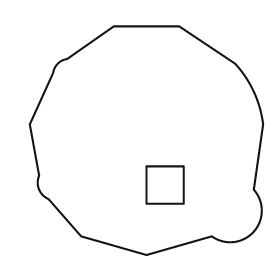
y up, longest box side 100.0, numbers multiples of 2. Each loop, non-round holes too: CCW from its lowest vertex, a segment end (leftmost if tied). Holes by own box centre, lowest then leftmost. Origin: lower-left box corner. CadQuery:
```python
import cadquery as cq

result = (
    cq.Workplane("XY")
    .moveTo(50.0, 0.0)
    .lineTo(78.0, 8.0)
    .threePointArc((96.0, 10.0), (96.0, 28.0))
    .lineTo(100.0, 56.0)
    .threePointArc((96.0, 70.0), (88.0, 82.0))
    .lineTo(64.0, 98.0)
    .lineTo(36.0, 98.0)
    .lineTo(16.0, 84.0)
    .threePointArc((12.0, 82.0), (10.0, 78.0))
    .lineTo(0.0, 56.0)
    .lineTo(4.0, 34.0)
    .threePointArc((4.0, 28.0), (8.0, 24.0))
    .lineTo(22.0, 8.0)
    .close()
    .moveTo(50.0, 22.0)
    .lineTo(66.0, 22.0)
    .lineTo(66.0, 38.0)
    .lineTo(50.0, 38.0)
    .close()
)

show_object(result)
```